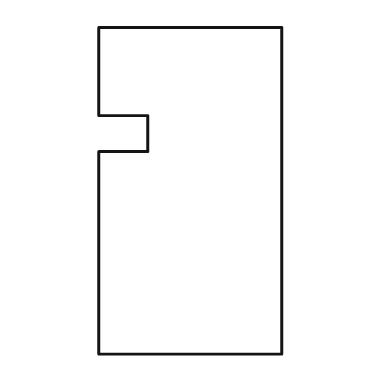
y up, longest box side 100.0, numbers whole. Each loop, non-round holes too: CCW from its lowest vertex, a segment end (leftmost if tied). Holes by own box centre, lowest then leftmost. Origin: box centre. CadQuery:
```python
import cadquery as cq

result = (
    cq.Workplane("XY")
    .moveTo(-28.0, -50.0)
    .lineTo(28.0, -50.0)
    .lineTo(28.0, 50.0)
    .lineTo(-28.0, 50.0)
    .lineTo(-28.0, 23.0)
    .lineTo(-13.0, 23.0)
    .lineTo(-13.0, 12.0)
    .lineTo(-28.0, 12.0)
    .close()
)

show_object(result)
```